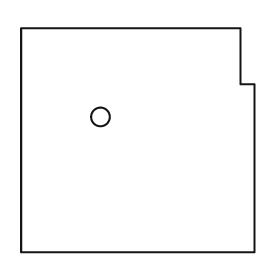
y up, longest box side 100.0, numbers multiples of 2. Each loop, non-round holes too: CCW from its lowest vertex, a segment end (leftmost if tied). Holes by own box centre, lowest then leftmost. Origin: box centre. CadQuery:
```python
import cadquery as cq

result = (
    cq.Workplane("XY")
    .moveTo(-50.0, -48.0)
    .lineTo(50.0, -48.0)
    .lineTo(50.0, 24.0)
    .lineTo(44.0, 24.0)
    .lineTo(44.0, 48.0)
    .lineTo(-50.0, 48.0)
    .close()
    .moveTo(-16.0, 10.0)
    .circle(4.0)
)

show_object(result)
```